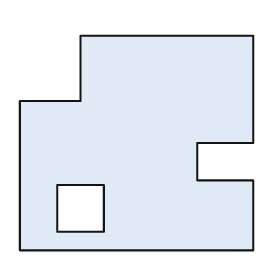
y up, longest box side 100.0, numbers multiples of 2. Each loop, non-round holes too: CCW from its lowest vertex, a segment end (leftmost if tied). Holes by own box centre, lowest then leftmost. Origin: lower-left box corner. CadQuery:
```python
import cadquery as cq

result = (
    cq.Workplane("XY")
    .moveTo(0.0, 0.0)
    .lineTo(100.0, 0.0)
    .lineTo(100.0, 30.0)
    .lineTo(76.0, 30.0)
    .lineTo(76.0, 46.0)
    .lineTo(100.0, 46.0)
    .lineTo(100.0, 92.0)
    .lineTo(26.0, 92.0)
    .lineTo(26.0, 64.0)
    .lineTo(0.0, 64.0)
    .close()
    .moveTo(16.0, 8.0)
    .lineTo(36.0, 8.0)
    .lineTo(36.0, 28.0)
    .lineTo(16.0, 28.0)
    .close()
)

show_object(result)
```